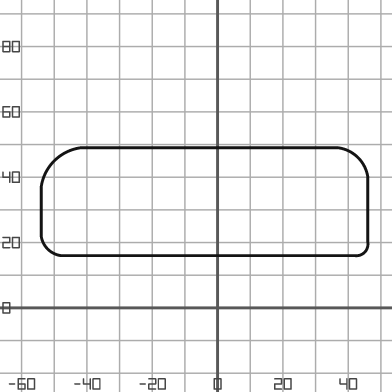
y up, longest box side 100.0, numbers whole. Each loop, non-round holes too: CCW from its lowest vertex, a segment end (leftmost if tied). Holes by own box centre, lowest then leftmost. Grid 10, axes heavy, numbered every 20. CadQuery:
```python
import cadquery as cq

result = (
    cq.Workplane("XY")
    .moveTo(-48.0, 16.0)
    .lineTo(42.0, 16.0)
    .threePointArc((45.0, 17.0), (46.0, 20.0))
    .lineTo(46.0, 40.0)
    .threePointArc((43.0, 46.0), (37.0, 49.0))
    .lineTo(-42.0, 49.0)
    .threePointArc((-50.0, 45.0), (-54.0, 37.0))
    .lineTo(-54.0, 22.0)
    .threePointArc((-52.0, 18.0), (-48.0, 16.0))
    .close()
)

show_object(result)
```